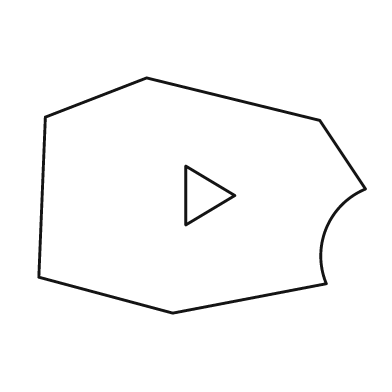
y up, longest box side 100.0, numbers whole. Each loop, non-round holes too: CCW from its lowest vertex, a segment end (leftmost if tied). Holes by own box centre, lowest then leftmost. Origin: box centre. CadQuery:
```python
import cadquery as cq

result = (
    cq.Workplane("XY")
    .moveTo(-9.0, -36.0)
    .lineTo(38.0, -27.0)
    .threePointArc((38.0, -10.0), (50.0, 2.0))
    .lineTo(36.0, 23.0)
    .lineTo(-17.0, 36.0)
    .lineTo(-48.0, 24.0)
    .lineTo(-50.0, -25.0)
    .close()
    .moveTo(-5.0, -9.0)
    .lineTo(10.0, 0.0)
    .lineTo(-5.0, 9.0)
    .close()
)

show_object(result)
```